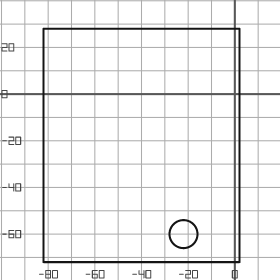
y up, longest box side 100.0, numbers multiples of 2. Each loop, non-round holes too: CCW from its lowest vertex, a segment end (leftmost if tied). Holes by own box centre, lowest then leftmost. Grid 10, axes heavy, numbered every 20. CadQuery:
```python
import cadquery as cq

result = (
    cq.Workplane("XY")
    .moveTo(-82.0, -72.0)
    .lineTo(2.0, -72.0)
    .lineTo(2.0, 28.0)
    .lineTo(-82.0, 28.0)
    .close()
    .moveTo(-22.0, -60.0)
    .circle(6.0)
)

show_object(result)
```